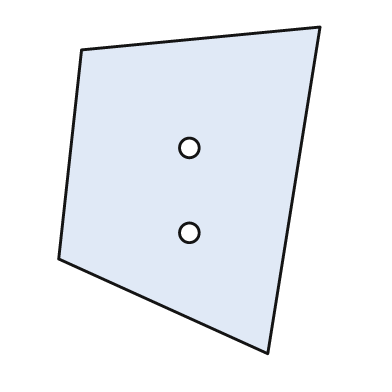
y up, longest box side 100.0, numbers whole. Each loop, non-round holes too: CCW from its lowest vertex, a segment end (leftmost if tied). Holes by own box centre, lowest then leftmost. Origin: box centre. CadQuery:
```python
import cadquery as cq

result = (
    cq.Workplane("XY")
    .moveTo(24.0, -50.0)
    .lineTo(40.0, 50.0)
    .lineTo(-33.0, 43.0)
    .lineTo(-40.0, -21.0)
    .close()
    .moveTo(0.0, -13.0)
    .circle(3.0)
    .moveTo(0.0, 13.0)
    .circle(3.0)
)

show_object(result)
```